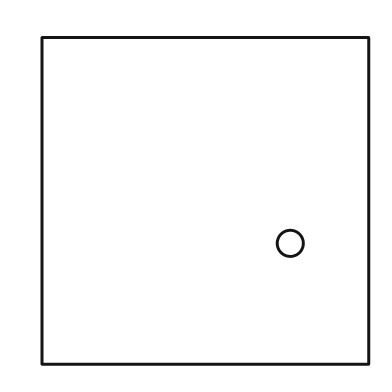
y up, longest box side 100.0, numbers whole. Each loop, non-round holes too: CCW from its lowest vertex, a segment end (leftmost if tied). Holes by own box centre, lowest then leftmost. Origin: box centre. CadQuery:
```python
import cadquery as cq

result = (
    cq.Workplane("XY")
    .moveTo(-50.0, -50.0)
    .lineTo(50.0, -50.0)
    .lineTo(50.0, 50.0)
    .lineTo(-50.0, 50.0)
    .close()
    .moveTo(26.0, -13.0)
    .circle(4.0)
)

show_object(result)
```